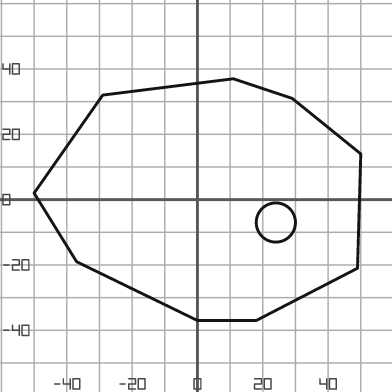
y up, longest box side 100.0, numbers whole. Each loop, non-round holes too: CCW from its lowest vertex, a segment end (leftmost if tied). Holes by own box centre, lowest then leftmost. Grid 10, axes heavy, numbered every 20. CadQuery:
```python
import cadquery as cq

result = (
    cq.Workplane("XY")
    .moveTo(0.0, -37.0)
    .lineTo(18.0, -37.0)
    .lineTo(49.0, -21.0)
    .lineTo(50.0, 14.0)
    .lineTo(29.0, 31.0)
    .lineTo(11.0, 37.0)
    .lineTo(-29.0, 32.0)
    .lineTo(-50.0, 2.0)
    .lineTo(-37.0, -19.0)
    .close()
    .moveTo(24.0, -7.0)
    .circle(6.0)
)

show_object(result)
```